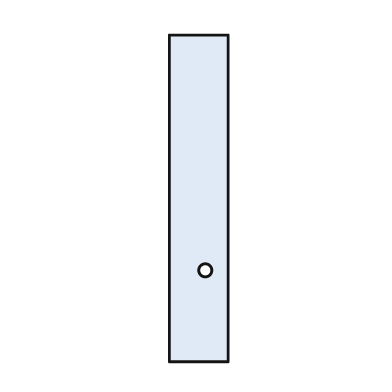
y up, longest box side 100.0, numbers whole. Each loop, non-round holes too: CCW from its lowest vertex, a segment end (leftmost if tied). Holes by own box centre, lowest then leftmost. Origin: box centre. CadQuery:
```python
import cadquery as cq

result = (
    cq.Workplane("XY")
    .moveTo(-9.0, -50.0)
    .lineTo(9.0, -50.0)
    .lineTo(9.0, 50.0)
    .lineTo(-9.0, 50.0)
    .close()
    .moveTo(2.0, -22.0)
    .circle(2.0)
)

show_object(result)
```